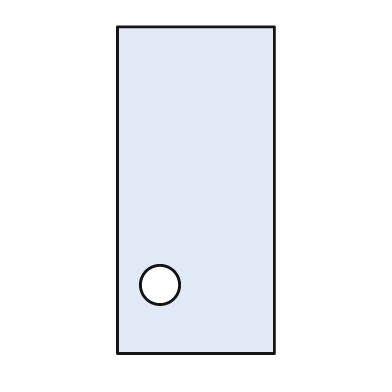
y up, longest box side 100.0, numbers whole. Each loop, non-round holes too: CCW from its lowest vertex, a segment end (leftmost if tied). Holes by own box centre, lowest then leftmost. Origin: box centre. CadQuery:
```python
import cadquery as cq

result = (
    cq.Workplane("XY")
    .moveTo(-24.0, -50.0)
    .lineTo(24.0, -50.0)
    .lineTo(24.0, 50.0)
    .lineTo(-24.0, 50.0)
    .close()
    .moveTo(-11.0, -29.0)
    .circle(6.0)
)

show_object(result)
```